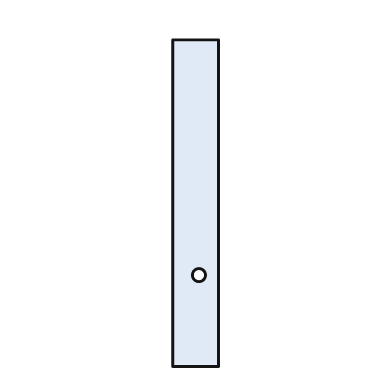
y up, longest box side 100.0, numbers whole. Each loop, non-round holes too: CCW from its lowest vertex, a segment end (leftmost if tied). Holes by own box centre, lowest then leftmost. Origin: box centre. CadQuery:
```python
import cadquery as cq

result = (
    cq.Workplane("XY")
    .moveTo(-7.0, -50.0)
    .lineTo(7.0, -50.0)
    .lineTo(7.0, 50.0)
    .lineTo(-7.0, 50.0)
    .close()
    .moveTo(1.0, -22.0)
    .circle(2.0)
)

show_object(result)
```